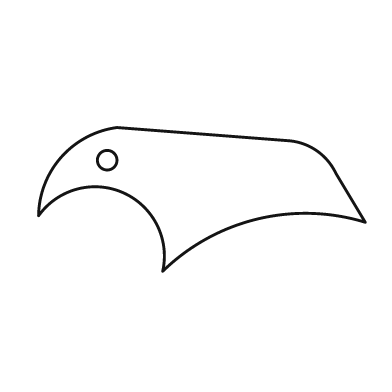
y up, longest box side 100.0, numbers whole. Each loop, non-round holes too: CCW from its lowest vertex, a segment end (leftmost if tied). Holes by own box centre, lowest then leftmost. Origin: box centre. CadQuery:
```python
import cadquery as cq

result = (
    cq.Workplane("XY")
    .moveTo(-12.0, -22.0)
    .threePointArc((17.0, -6.0), (50.0, -7.0))
    .lineTo(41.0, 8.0)
    .threePointArc((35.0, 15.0), (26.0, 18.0))
    .lineTo(-26.0, 22.0)
    .threePointArc((-43.0, 13.0), (-50.0, -5.0))
    .threePointArc((-24.0, 2.0), (-12.0, -22.0))
    .close()
    .moveTo(-29.0, 12.0)
    .circle(3.0)
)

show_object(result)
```